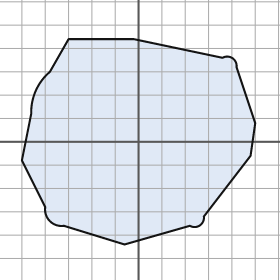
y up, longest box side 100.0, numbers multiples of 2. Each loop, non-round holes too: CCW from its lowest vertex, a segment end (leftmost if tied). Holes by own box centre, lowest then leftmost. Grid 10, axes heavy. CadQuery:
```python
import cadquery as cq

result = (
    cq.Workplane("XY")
    .moveTo(-6.0, -44.0)
    .lineTo(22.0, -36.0)
    .threePointArc((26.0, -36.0), (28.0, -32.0))
    .lineTo(48.0, -6.0)
    .lineTo(50.0, 8.0)
    .lineTo(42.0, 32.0)
    .threePointArc((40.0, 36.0), (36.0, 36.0))
    .lineTo(-2.0, 44.0)
    .lineTo(-30.0, 44.0)
    .lineTo(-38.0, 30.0)
    .threePointArc((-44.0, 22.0), (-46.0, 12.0))
    .lineTo(-50.0, -8.0)
    .lineTo(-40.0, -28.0)
    .threePointArc((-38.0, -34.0), (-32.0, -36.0))
    .close()
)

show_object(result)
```